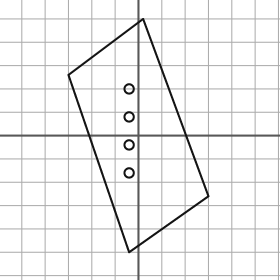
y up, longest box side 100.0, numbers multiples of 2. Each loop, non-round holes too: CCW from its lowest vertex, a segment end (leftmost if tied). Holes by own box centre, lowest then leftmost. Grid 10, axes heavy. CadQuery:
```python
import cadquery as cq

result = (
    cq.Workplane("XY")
    .moveTo(-4.0, -50.0)
    .lineTo(30.0, -26.0)
    .lineTo(2.0, 50.0)
    .lineTo(-30.0, 26.0)
    .close()
    .moveTo(-4.0, -16.0)
    .circle(2.0)
    .moveTo(-4.0, -4.0)
    .circle(2.0)
    .moveTo(-4.0, 8.0)
    .circle(2.0)
    .moveTo(-4.0, 20.0)
    .circle(2.0)
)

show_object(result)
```